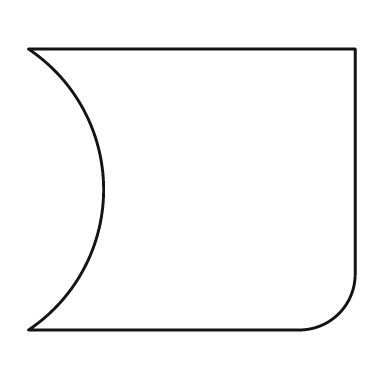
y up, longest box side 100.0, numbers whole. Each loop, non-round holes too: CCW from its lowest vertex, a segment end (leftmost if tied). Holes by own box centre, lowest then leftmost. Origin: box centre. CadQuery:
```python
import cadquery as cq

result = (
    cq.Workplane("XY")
    .moveTo(-50.0, -43.0)
    .lineTo(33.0, -43.0)
    .threePointArc((45.0, -38.0), (50.0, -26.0))
    .lineTo(50.0, 43.0)
    .lineTo(-50.0, 43.0)
    .threePointArc((-27.0, 0.0), (-50.0, -43.0))
    .close()
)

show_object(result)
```